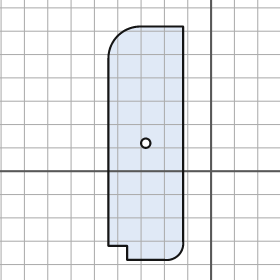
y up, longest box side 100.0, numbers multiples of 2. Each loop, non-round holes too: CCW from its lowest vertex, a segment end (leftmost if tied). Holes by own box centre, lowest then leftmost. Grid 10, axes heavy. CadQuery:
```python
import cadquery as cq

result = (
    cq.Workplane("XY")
    .moveTo(-36.0, -38.0)
    .lineTo(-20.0, -38.0)
    .threePointArc((-14.0, -36.0), (-12.0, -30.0))
    .lineTo(-12.0, 62.0)
    .lineTo(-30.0, 62.0)
    .threePointArc((-40.0, 58.0), (-44.0, 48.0))
    .lineTo(-44.0, -32.0)
    .lineTo(-36.0, -32.0)
    .close()
    .moveTo(-28.0, 12.0)
    .circle(2.0)
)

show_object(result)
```